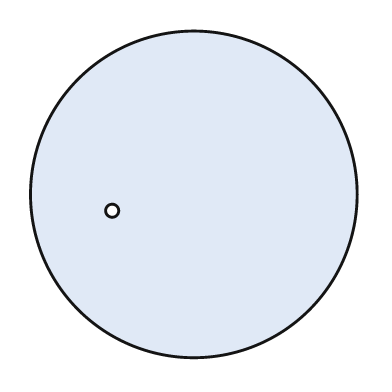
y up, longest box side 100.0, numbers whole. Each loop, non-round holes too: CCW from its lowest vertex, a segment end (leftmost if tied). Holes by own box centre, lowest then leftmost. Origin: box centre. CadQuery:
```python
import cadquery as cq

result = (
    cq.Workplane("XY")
    .moveTo(0.0, 0.0)
    .circle(50.0)
    .moveTo(-25.0, -5.0)
    .circle(2.0)
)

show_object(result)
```